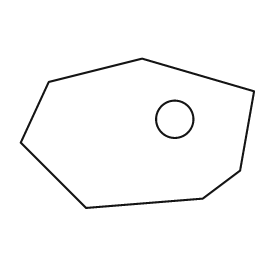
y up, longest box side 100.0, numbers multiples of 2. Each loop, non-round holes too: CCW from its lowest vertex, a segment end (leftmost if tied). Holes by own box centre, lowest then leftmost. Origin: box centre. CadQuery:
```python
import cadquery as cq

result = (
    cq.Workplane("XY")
    .moveTo(-22.0, -32.0)
    .lineTo(28.0, -28.0)
    .lineTo(44.0, -16.0)
    .lineTo(50.0, 18.0)
    .lineTo(2.0, 32.0)
    .lineTo(-38.0, 22.0)
    .lineTo(-50.0, -4.0)
    .close()
    .moveTo(16.0, 6.0)
    .circle(8.0)
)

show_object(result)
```